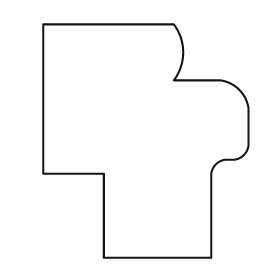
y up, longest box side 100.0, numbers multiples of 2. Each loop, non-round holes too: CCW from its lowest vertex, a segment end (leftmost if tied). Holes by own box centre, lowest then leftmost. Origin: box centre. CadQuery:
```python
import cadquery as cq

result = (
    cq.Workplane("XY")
    .moveTo(-18.0, -50.0)
    .lineTo(28.0, -50.0)
    .lineTo(28.0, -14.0)
    .threePointArc((30.0, -10.0), (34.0, -8.0))
    .lineTo(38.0, -8.0)
    .threePointArc((42.0, -6.0), (44.0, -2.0))
    .lineTo(44.0, 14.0)
    .threePointArc((40.0, 22.0), (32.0, 26.0))
    .lineTo(12.0, 26.0)
    .threePointArc((16.0, 38.0), (12.0, 50.0))
    .lineTo(-44.0, 50.0)
    .lineTo(-44.0, -14.0)
    .lineTo(-18.0, -14.0)
    .close()
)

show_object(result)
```